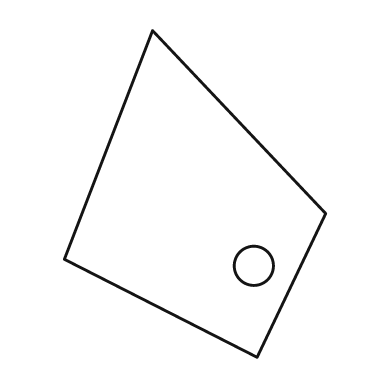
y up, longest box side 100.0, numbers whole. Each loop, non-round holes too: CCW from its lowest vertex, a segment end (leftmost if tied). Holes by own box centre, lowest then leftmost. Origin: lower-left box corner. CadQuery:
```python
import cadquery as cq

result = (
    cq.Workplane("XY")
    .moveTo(59.0, 0.0)
    .lineTo(80.0, 44.0)
    .lineTo(27.0, 100.0)
    .lineTo(0.0, 30.0)
    .close()
    .moveTo(58.0, 28.0)
    .circle(6.0)
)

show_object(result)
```